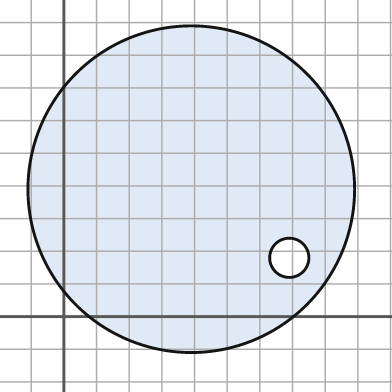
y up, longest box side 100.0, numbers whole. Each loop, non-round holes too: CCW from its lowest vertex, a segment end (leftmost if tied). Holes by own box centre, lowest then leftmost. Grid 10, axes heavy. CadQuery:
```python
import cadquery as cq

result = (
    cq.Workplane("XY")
    .moveTo(39.0, 39.0)
    .circle(50.0)
    .moveTo(69.0, 18.0)
    .circle(6.0)
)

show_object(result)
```